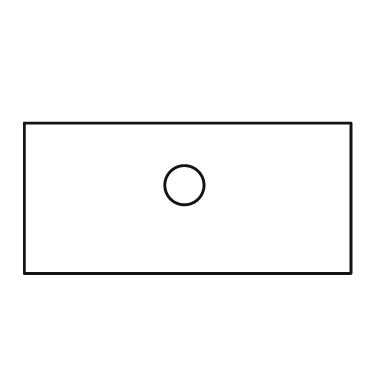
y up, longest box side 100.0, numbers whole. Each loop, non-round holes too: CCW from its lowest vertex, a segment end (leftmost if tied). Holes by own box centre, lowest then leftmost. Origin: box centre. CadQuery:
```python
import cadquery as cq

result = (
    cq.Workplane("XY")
    .moveTo(-50.0, -23.0)
    .lineTo(50.0, -23.0)
    .lineTo(50.0, 23.0)
    .lineTo(-50.0, 23.0)
    .close()
    .moveTo(-1.0, 4.0)
    .circle(6.0)
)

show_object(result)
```